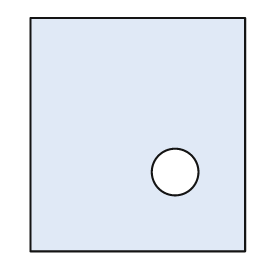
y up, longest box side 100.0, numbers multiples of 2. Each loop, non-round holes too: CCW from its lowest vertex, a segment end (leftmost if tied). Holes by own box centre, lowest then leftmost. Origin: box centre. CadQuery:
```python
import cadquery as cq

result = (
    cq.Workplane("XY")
    .moveTo(-46.0, -50.0)
    .lineTo(46.0, -50.0)
    .lineTo(46.0, 50.0)
    .lineTo(-46.0, 50.0)
    .close()
    .moveTo(16.0, -16.0)
    .circle(10.0)
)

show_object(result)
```